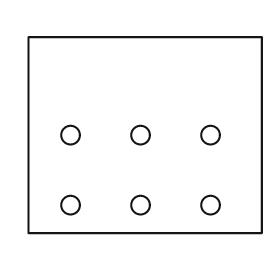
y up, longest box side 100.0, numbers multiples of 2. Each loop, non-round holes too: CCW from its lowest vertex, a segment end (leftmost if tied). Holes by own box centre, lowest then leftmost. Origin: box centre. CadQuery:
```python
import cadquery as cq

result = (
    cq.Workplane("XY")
    .moveTo(-50.0, -42.0)
    .lineTo(50.0, -42.0)
    .lineTo(50.0, 42.0)
    .lineTo(-50.0, 42.0)
    .close()
    .moveTo(-32.0, -30.0)
    .circle(4.0)
    .moveTo(-2.0, -30.0)
    .circle(4.0)
    .moveTo(28.0, -30.0)
    .circle(4.0)
    .moveTo(-32.0, 0.0)
    .circle(4.0)
    .moveTo(-2.0, 0.0)
    .circle(4.0)
    .moveTo(28.0, 0.0)
    .circle(4.0)
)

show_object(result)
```